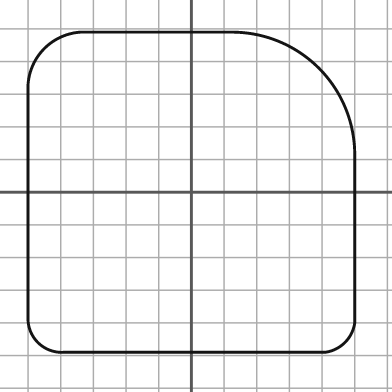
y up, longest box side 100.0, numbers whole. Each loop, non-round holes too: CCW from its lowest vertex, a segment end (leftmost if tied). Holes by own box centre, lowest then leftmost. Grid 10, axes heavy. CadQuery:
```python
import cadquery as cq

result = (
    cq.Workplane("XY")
    .moveTo(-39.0, -49.0)
    .lineTo(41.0, -49.0)
    .threePointArc((47.0, -46.0), (50.0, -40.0))
    .lineTo(50.0, 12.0)
    .threePointArc((39.0, 38.0), (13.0, 49.0))
    .lineTo(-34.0, 49.0)
    .threePointArc((-45.0, 44.0), (-50.0, 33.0))
    .lineTo(-50.0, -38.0)
    .threePointArc((-47.0, -46.0), (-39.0, -49.0))
    .close()
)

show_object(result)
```